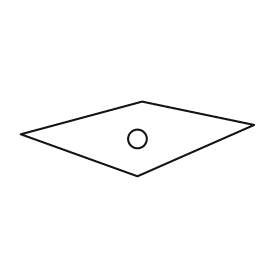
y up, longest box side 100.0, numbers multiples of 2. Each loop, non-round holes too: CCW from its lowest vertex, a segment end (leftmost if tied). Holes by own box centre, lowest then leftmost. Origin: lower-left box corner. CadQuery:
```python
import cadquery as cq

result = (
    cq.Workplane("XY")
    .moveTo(50.0, 0.0)
    .lineTo(100.0, 22.0)
    .lineTo(52.0, 32.0)
    .lineTo(0.0, 18.0)
    .close()
    .moveTo(50.0, 16.0)
    .circle(4.0)
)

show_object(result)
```